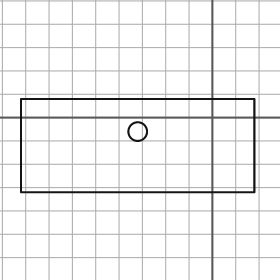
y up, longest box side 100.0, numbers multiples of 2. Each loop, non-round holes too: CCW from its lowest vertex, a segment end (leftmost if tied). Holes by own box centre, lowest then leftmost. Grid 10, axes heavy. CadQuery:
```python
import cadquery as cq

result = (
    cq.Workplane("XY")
    .moveTo(-82.0, -32.0)
    .lineTo(18.0, -32.0)
    .lineTo(18.0, 8.0)
    .lineTo(-82.0, 8.0)
    .close()
    .moveTo(-32.0, -6.0)
    .circle(4.0)
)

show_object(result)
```